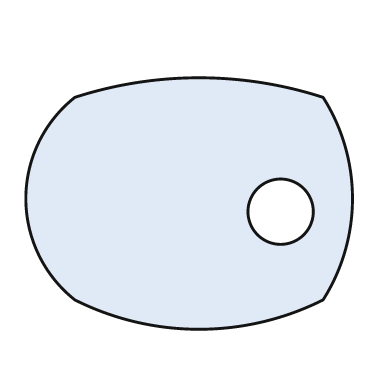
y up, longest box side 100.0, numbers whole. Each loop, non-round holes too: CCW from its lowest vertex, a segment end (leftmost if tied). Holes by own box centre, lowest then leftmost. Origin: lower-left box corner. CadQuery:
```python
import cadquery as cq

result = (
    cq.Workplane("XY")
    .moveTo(15.0, 9.0)
    .threePointArc((53.0, 0.0), (91.0, 9.0))
    .threePointArc((100.0, 40.0), (91.0, 71.0))
    .threePointArc((53.0, 77.0), (15.0, 71.0))
    .threePointArc((0.0, 40.0), (15.0, 9.0))
    .close()
    .moveTo(78.0, 36.0)
    .circle(10.0)
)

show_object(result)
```